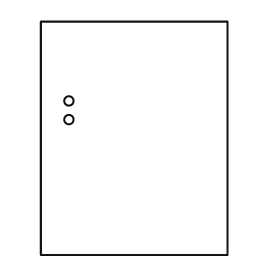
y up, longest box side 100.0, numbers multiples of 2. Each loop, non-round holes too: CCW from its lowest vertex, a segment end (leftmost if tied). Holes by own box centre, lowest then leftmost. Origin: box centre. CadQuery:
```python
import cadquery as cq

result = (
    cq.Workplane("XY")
    .moveTo(-40.0, -50.0)
    .lineTo(40.0, -50.0)
    .lineTo(40.0, 50.0)
    .lineTo(-40.0, 50.0)
    .close()
    .moveTo(-28.0, 8.0)
    .circle(2.0)
    .moveTo(-28.0, 16.0)
    .circle(2.0)
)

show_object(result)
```